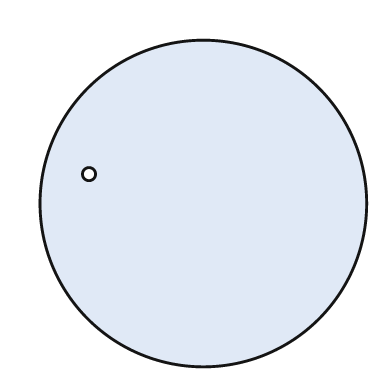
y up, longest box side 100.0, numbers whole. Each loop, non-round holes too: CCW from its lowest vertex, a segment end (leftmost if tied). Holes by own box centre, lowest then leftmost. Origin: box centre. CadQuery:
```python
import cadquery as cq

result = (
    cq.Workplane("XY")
    .moveTo(0.0, 0.0)
    .circle(50.0)
    .moveTo(-35.0, 9.0)
    .circle(2.0)
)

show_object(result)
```